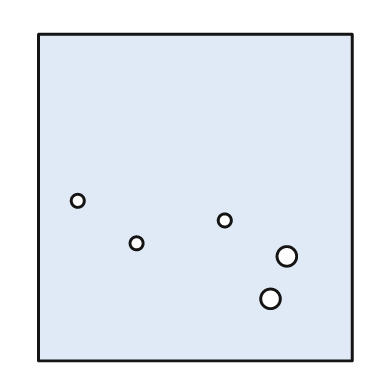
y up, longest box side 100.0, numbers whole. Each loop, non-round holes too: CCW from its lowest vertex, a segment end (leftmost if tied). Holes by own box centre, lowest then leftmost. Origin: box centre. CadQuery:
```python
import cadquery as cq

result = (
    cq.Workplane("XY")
    .moveTo(-48.0, -50.0)
    .lineTo(48.0, -50.0)
    .lineTo(48.0, 50.0)
    .lineTo(-48.0, 50.0)
    .close()
    .moveTo(23.0, -31.0)
    .circle(3.0)
    .moveTo(28.0, -18.0)
    .circle(3.0)
    .moveTo(-18.0, -14.0)
    .circle(2.0)
    .moveTo(9.0, -7.0)
    .circle(2.0)
    .moveTo(-36.0, -1.0)
    .circle(2.0)
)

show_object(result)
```